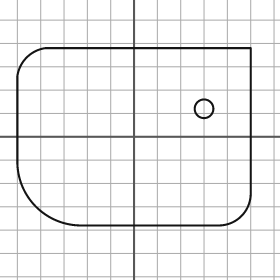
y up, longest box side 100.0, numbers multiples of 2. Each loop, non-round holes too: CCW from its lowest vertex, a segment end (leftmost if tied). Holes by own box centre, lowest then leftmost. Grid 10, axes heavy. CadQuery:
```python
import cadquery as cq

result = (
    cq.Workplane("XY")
    .moveTo(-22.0, -38.0)
    .lineTo(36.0, -38.0)
    .threePointArc((46.0, -34.0), (50.0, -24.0))
    .lineTo(50.0, 38.0)
    .lineTo(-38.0, 38.0)
    .threePointArc((-46.0, 34.0), (-50.0, 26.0))
    .lineTo(-50.0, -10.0)
    .threePointArc((-42.0, -30.0), (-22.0, -38.0))
    .close()
    .moveTo(30.0, 12.0)
    .circle(4.0)
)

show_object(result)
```